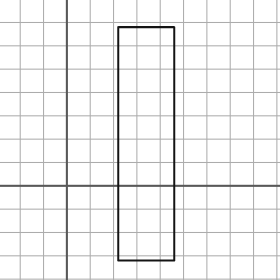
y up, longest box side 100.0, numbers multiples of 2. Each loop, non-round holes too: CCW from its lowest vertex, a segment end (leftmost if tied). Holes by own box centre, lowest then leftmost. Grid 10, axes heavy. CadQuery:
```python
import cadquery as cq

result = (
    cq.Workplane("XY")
    .moveTo(22.0, -32.0)
    .lineTo(46.0, -32.0)
    .lineTo(46.0, 68.0)
    .lineTo(22.0, 68.0)
    .close()
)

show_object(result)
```